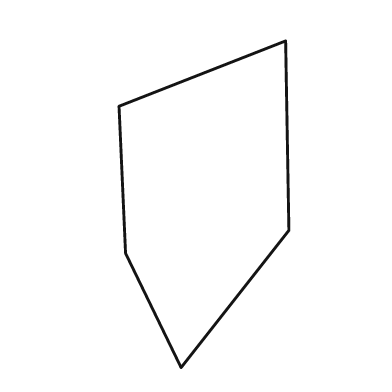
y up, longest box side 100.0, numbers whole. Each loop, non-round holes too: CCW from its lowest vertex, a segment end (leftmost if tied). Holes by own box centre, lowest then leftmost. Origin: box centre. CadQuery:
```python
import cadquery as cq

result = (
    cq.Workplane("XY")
    .moveTo(-7.0, -50.0)
    .lineTo(26.0, -8.0)
    .lineTo(25.0, 50.0)
    .lineTo(-26.0, 30.0)
    .lineTo(-24.0, -15.0)
    .close()
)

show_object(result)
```